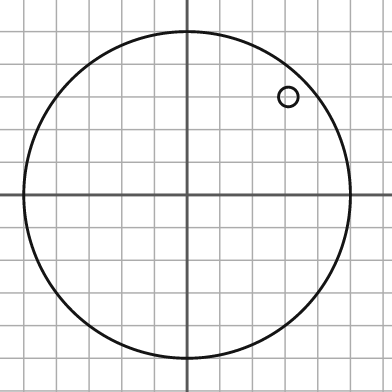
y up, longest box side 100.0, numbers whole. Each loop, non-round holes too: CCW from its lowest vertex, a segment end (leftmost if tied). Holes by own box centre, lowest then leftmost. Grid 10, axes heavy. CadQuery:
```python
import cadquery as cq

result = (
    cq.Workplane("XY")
    .moveTo(0.0, 0.0)
    .circle(50.0)
    .moveTo(31.0, 30.0)
    .circle(3.0)
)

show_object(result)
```